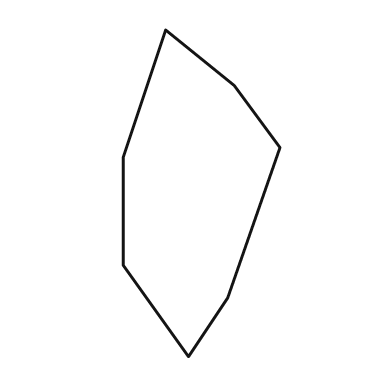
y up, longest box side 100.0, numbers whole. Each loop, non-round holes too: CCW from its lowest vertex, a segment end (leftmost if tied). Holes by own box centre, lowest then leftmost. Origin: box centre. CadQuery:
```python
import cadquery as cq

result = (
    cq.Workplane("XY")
    .moveTo(-4.0, -50.0)
    .lineTo(8.0, -32.0)
    .lineTo(24.0, 14.0)
    .lineTo(10.0, 33.0)
    .lineTo(-11.0, 50.0)
    .lineTo(-24.0, 11.0)
    .lineTo(-24.0, -22.0)
    .close()
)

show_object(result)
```